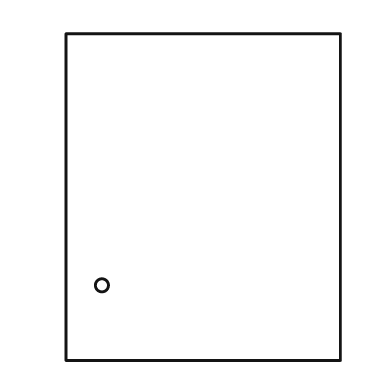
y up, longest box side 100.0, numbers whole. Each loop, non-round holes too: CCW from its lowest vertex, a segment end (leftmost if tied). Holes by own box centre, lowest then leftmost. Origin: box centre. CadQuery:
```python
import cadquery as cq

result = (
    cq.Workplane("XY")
    .moveTo(-42.0, -50.0)
    .lineTo(42.0, -50.0)
    .lineTo(42.0, 50.0)
    .lineTo(-42.0, 50.0)
    .close()
    .moveTo(-31.0, -27.0)
    .circle(2.0)
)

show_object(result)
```